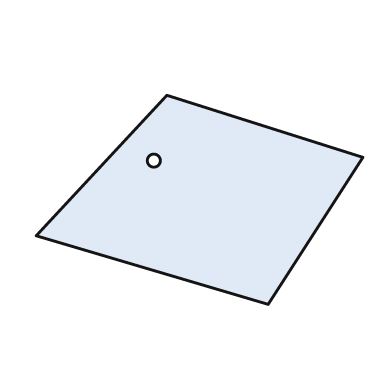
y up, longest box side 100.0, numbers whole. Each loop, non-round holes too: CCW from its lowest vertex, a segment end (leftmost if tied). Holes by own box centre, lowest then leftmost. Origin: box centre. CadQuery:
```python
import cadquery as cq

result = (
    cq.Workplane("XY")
    .moveTo(21.0, -32.0)
    .lineTo(50.0, 13.0)
    .lineTo(-10.0, 32.0)
    .lineTo(-50.0, -11.0)
    .close()
    .moveTo(-14.0, 12.0)
    .circle(2.0)
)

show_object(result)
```